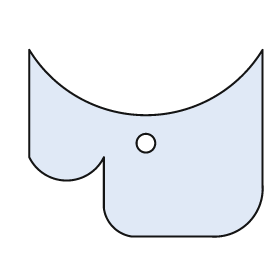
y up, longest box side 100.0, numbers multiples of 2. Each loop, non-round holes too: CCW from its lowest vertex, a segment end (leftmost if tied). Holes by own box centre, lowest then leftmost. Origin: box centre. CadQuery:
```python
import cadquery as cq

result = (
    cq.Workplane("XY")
    .moveTo(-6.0, -40.0)
    .lineTo(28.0, -40.0)
    .threePointArc((44.0, -34.0), (50.0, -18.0))
    .lineTo(50.0, 40.0)
    .threePointArc((0.0, 12.0), (-50.0, 40.0))
    .lineTo(-50.0, -6.0)
    .threePointArc((-34.0, -16.0), (-18.0, -6.0))
    .lineTo(-18.0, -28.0)
    .threePointArc((-14.0, -36.0), (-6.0, -40.0))
    .close()
    .moveTo(0.0, 0.0)
    .circle(4.0)
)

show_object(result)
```